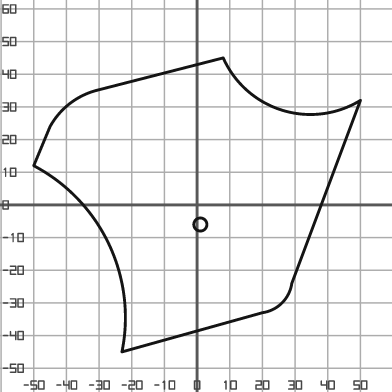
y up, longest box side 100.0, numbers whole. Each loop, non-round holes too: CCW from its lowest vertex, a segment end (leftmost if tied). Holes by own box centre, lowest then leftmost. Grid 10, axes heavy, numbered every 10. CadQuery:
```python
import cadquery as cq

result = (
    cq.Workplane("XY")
    .moveTo(-23.0, -45.0)
    .lineTo(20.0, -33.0)
    .threePointArc((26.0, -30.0), (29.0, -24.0))
    .lineTo(50.0, 32.0)
    .threePointArc((26.0, 29.0), (8.0, 45.0))
    .lineTo(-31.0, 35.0)
    .threePointArc((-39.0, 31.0), (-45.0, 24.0))
    .lineTo(-50.0, 12.0)
    .threePointArc((-27.0, -12.0), (-23.0, -45.0))
    .close()
    .moveTo(1.0, -6.0)
    .circle(2.0)
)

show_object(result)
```